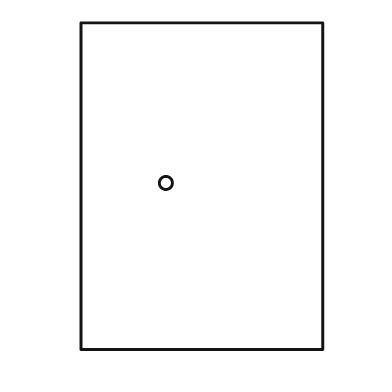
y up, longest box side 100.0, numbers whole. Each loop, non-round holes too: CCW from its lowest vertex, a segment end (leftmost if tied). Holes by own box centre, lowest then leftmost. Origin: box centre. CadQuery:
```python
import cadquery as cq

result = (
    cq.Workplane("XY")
    .moveTo(-37.0, -50.0)
    .lineTo(37.0, -50.0)
    .lineTo(37.0, 50.0)
    .lineTo(-37.0, 50.0)
    .close()
    .moveTo(-11.0, 1.0)
    .circle(2.0)
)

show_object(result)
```